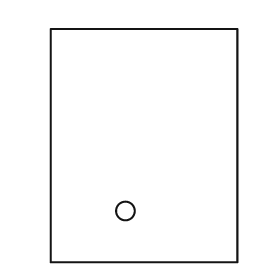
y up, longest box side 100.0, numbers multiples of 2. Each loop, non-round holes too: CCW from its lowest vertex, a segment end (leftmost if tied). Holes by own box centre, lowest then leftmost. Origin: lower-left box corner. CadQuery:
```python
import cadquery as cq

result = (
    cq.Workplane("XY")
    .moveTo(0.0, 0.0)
    .lineTo(80.0, 0.0)
    .lineTo(80.0, 100.0)
    .lineTo(0.0, 100.0)
    .close()
    .moveTo(32.0, 22.0)
    .circle(4.0)
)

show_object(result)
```